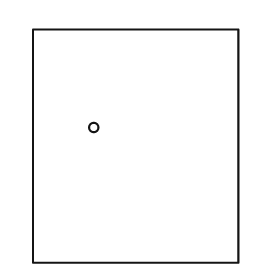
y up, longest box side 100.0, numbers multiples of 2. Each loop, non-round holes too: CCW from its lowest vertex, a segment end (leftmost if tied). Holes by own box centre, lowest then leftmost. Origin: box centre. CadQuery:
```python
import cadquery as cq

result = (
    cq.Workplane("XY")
    .moveTo(-44.0, -50.0)
    .lineTo(44.0, -50.0)
    .lineTo(44.0, 50.0)
    .lineTo(-44.0, 50.0)
    .close()
    .moveTo(-18.0, 8.0)
    .circle(2.0)
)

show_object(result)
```